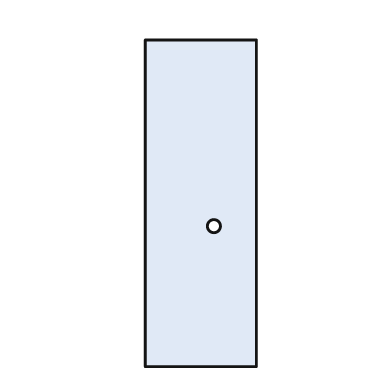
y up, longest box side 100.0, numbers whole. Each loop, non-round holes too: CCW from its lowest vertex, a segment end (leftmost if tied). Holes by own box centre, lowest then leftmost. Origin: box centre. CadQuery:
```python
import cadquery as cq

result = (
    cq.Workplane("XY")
    .moveTo(-17.0, -50.0)
    .lineTo(17.0, -50.0)
    .lineTo(17.0, 50.0)
    .lineTo(-17.0, 50.0)
    .close()
    .moveTo(4.0, -7.0)
    .circle(2.0)
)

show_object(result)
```